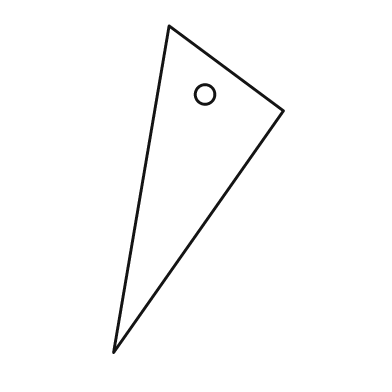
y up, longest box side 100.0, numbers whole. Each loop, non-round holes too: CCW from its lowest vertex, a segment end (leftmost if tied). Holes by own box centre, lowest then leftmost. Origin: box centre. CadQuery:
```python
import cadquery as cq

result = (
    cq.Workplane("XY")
    .moveTo(-26.0, -50.0)
    .lineTo(26.0, 24.0)
    .lineTo(-9.0, 50.0)
    .close()
    .moveTo(2.0, 29.0)
    .circle(3.0)
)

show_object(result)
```